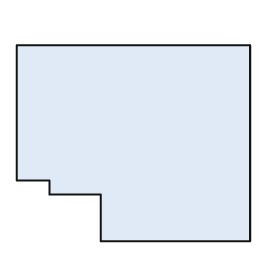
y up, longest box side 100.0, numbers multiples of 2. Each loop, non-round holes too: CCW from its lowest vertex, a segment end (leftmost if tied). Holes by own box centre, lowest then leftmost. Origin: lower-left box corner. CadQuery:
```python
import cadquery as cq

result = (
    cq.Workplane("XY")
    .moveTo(36.0, 0.0)
    .lineTo(100.0, 0.0)
    .lineTo(100.0, 84.0)
    .lineTo(0.0, 84.0)
    .lineTo(0.0, 26.0)
    .lineTo(14.0, 26.0)
    .lineTo(14.0, 20.0)
    .lineTo(36.0, 20.0)
    .close()
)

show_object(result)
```